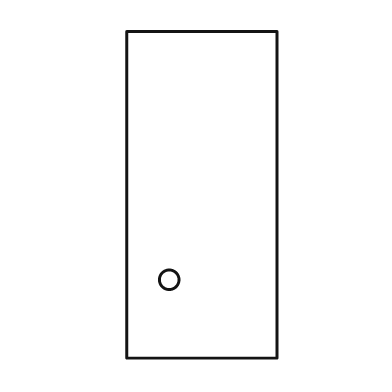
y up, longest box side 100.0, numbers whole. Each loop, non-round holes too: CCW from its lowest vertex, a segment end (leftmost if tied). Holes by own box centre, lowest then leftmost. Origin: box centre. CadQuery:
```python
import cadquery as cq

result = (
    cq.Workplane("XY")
    .moveTo(-23.0, -50.0)
    .lineTo(23.0, -50.0)
    .lineTo(23.0, 50.0)
    .lineTo(-23.0, 50.0)
    .close()
    .moveTo(-10.0, -26.0)
    .circle(3.0)
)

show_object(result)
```